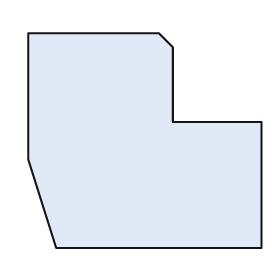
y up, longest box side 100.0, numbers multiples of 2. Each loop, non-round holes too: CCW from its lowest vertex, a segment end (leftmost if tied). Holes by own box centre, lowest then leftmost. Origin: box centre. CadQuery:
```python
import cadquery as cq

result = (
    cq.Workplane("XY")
    .moveTo(-38.0, -46.0)
    .lineTo(50.0, -46.0)
    .lineTo(50.0, 8.0)
    .lineTo(12.0, 8.0)
    .lineTo(12.0, 40.0)
    .lineTo(6.0, 46.0)
    .lineTo(-50.0, 46.0)
    .lineTo(-50.0, -8.0)
    .close()
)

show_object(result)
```